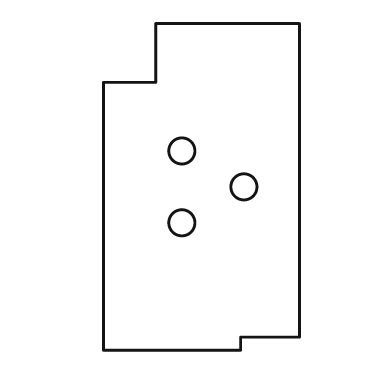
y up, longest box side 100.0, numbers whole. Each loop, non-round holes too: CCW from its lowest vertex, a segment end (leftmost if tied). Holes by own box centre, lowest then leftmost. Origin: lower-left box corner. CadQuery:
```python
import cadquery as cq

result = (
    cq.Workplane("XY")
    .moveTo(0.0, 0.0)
    .lineTo(42.0, 0.0)
    .lineTo(42.0, 4.0)
    .lineTo(60.0, 4.0)
    .lineTo(60.0, 100.0)
    .lineTo(16.0, 100.0)
    .lineTo(16.0, 82.0)
    .lineTo(0.0, 82.0)
    .close()
    .moveTo(24.0, 39.0)
    .circle(4.0)
    .moveTo(43.0, 50.0)
    .circle(4.0)
    .moveTo(24.0, 61.0)
    .circle(4.0)
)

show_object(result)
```